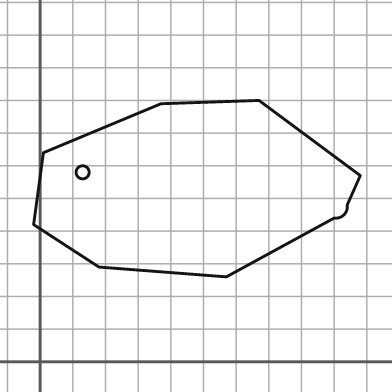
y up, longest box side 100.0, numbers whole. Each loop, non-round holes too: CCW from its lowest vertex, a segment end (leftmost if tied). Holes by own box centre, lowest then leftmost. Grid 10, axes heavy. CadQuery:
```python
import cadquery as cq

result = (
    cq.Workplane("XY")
    .moveTo(57.0, 26.0)
    .lineTo(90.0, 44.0)
    .threePointArc((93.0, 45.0), (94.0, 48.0))
    .lineTo(98.0, 57.0)
    .lineTo(67.0, 80.0)
    .lineTo(37.0, 79.0)
    .lineTo(1.0, 64.0)
    .lineTo(-2.0, 42.0)
    .lineTo(18.0, 29.0)
    .close()
    .moveTo(13.0, 58.0)
    .circle(2.0)
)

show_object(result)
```